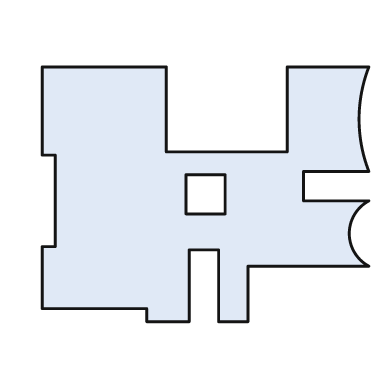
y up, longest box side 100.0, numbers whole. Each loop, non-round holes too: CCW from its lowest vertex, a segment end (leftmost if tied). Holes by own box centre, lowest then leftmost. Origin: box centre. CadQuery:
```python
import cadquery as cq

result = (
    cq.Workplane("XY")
    .moveTo(-18.0, -39.0)
    .lineTo(-5.0, -39.0)
    .lineTo(-5.0, -17.0)
    .lineTo(4.0, -17.0)
    .lineTo(4.0, -39.0)
    .lineTo(13.0, -39.0)
    .lineTo(13.0, -22.0)
    .lineTo(50.0, -22.0)
    .threePointArc((44.0, -12.0), (50.0, -2.0))
    .lineTo(30.0, -2.0)
    .lineTo(30.0, 7.0)
    .lineTo(50.0, 7.0)
    .threePointArc((47.0, 23.0), (50.0, 39.0))
    .lineTo(25.0, 39.0)
    .lineTo(25.0, 13.0)
    .lineTo(-12.0, 13.0)
    .lineTo(-12.0, 39.0)
    .lineTo(-50.0, 39.0)
    .lineTo(-50.0, 12.0)
    .lineTo(-46.0, 12.0)
    .lineTo(-46.0, -16.0)
    .lineTo(-50.0, -16.0)
    .lineTo(-50.0, -35.0)
    .lineTo(-18.0, -35.0)
    .close()
    .moveTo(-6.0, -6.0)
    .lineTo(6.0, -6.0)
    .lineTo(6.0, 6.0)
    .lineTo(-6.0, 6.0)
    .close()
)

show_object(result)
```